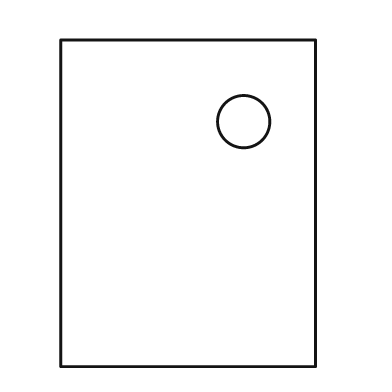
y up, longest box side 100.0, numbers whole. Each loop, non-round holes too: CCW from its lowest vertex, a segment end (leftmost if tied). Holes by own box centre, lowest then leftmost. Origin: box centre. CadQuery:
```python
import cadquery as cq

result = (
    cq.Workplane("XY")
    .moveTo(-39.0, -50.0)
    .lineTo(39.0, -50.0)
    .lineTo(39.0, 50.0)
    .lineTo(-39.0, 50.0)
    .close()
    .moveTo(17.0, 25.0)
    .circle(8.0)
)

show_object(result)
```